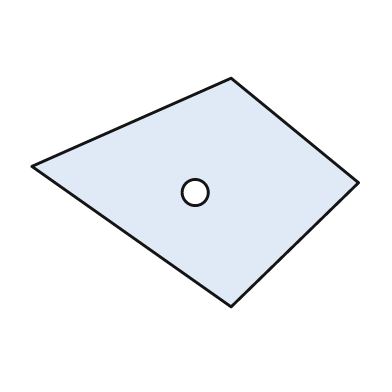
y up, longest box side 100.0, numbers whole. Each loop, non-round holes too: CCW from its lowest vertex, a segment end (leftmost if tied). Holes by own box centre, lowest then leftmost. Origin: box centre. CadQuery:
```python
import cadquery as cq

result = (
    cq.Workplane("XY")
    .moveTo(11.0, -35.0)
    .lineTo(50.0, 3.0)
    .lineTo(11.0, 35.0)
    .lineTo(-50.0, 8.0)
    .close()
    .moveTo(0.0, 0.0)
    .circle(4.0)
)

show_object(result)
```